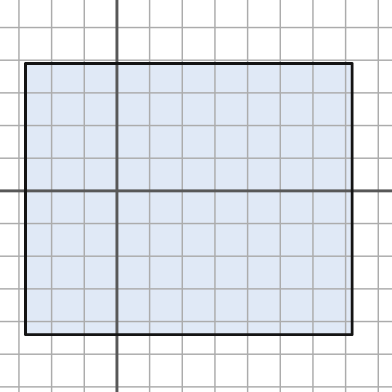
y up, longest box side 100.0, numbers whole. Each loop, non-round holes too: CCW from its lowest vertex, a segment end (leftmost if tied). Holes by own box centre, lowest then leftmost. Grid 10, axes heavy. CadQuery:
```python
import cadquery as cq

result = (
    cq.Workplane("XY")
    .moveTo(-28.0, -44.0)
    .lineTo(72.0, -44.0)
    .lineTo(72.0, 39.0)
    .lineTo(-28.0, 39.0)
    .close()
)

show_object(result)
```